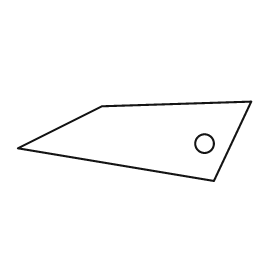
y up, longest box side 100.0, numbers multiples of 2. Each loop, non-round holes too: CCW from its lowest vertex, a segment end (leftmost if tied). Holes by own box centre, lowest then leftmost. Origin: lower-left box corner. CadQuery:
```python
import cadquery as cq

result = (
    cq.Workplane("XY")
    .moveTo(84.0, 0.0)
    .lineTo(100.0, 34.0)
    .lineTo(36.0, 32.0)
    .lineTo(0.0, 14.0)
    .close()
    .moveTo(80.0, 16.0)
    .circle(4.0)
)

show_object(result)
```